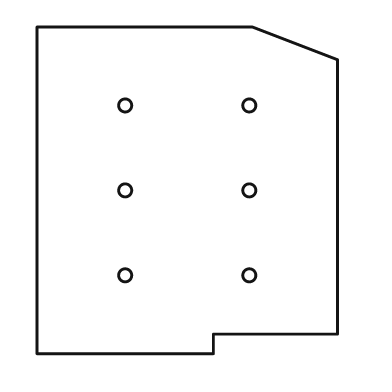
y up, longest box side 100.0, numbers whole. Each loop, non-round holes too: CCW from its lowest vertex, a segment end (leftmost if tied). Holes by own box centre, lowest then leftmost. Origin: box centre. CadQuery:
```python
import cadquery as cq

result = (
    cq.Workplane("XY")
    .moveTo(-46.0, -50.0)
    .lineTo(8.0, -50.0)
    .lineTo(8.0, -44.0)
    .lineTo(46.0, -44.0)
    .lineTo(46.0, 40.0)
    .lineTo(20.0, 50.0)
    .lineTo(-46.0, 50.0)
    .close()
    .moveTo(-19.0, -26.0)
    .circle(2.0)
    .moveTo(19.0, -26.0)
    .circle(2.0)
    .moveTo(-19.0, 0.0)
    .circle(2.0)
    .moveTo(19.0, 0.0)
    .circle(2.0)
    .moveTo(-19.0, 26.0)
    .circle(2.0)
    .moveTo(19.0, 26.0)
    .circle(2.0)
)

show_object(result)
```